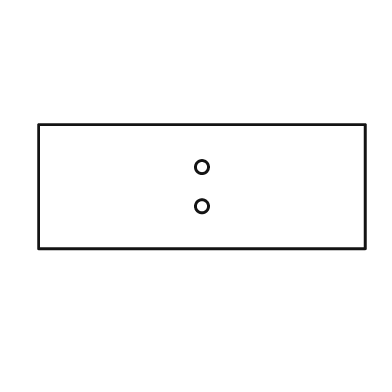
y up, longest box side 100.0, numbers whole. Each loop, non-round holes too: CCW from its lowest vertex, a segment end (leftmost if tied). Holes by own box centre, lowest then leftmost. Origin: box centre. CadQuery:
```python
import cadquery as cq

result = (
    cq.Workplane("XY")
    .moveTo(-50.0, -19.0)
    .lineTo(50.0, -19.0)
    .lineTo(50.0, 19.0)
    .lineTo(-50.0, 19.0)
    .close()
    .moveTo(0.0, -6.0)
    .circle(2.0)
    .moveTo(0.0, 6.0)
    .circle(2.0)
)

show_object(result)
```